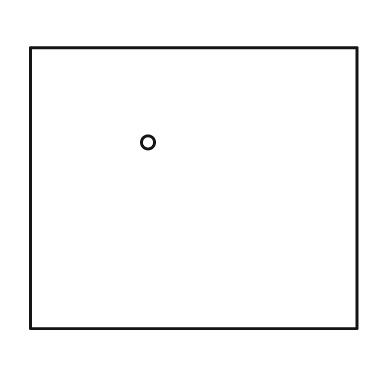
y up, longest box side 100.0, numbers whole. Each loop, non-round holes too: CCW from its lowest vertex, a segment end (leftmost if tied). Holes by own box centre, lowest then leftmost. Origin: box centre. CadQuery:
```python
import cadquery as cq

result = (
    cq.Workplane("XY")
    .moveTo(-50.0, -43.0)
    .lineTo(50.0, -43.0)
    .lineTo(50.0, 43.0)
    .lineTo(-50.0, 43.0)
    .close()
    .moveTo(-14.0, 14.0)
    .circle(2.0)
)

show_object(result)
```